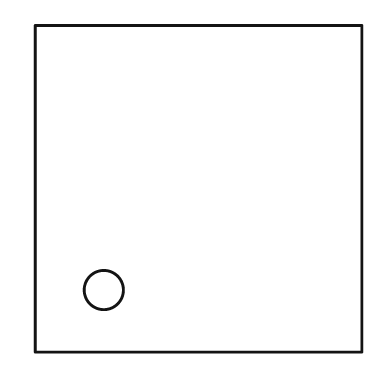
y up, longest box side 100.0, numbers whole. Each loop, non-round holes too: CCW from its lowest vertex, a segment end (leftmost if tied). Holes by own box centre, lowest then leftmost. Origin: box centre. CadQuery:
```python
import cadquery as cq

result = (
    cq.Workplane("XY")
    .moveTo(-50.0, -50.0)
    .lineTo(50.0, -50.0)
    .lineTo(50.0, 50.0)
    .lineTo(-50.0, 50.0)
    .close()
    .moveTo(-29.0, -31.0)
    .circle(6.0)
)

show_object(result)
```